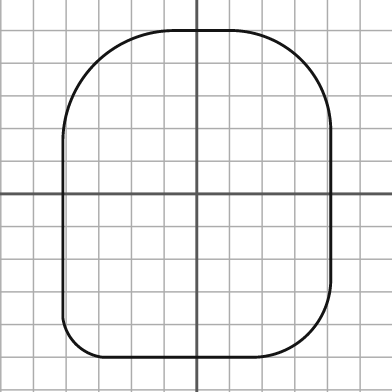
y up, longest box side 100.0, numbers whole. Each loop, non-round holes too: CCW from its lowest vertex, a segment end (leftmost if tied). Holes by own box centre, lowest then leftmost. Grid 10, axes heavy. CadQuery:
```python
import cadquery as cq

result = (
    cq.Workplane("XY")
    .moveTo(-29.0, -50.0)
    .lineTo(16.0, -50.0)
    .threePointArc((34.0, -43.0), (41.0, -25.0))
    .lineTo(41.0, 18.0)
    .threePointArc((32.0, 41.0), (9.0, 50.0))
    .lineTo(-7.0, 50.0)
    .threePointArc((-31.0, 40.0), (-41.0, 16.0))
    .lineTo(-41.0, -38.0)
    .threePointArc((-37.0, -46.0), (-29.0, -50.0))
    .close()
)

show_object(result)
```